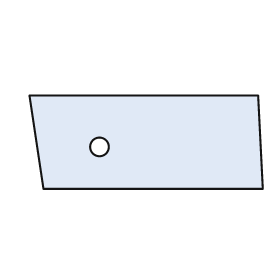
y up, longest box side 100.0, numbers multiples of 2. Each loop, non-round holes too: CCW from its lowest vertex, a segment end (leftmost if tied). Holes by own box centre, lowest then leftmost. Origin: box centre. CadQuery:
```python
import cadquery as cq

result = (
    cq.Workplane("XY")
    .moveTo(-44.0, -20.0)
    .lineTo(50.0, -20.0)
    .lineTo(48.0, 20.0)
    .lineTo(-50.0, 20.0)
    .close()
    .moveTo(-20.0, -2.0)
    .circle(4.0)
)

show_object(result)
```